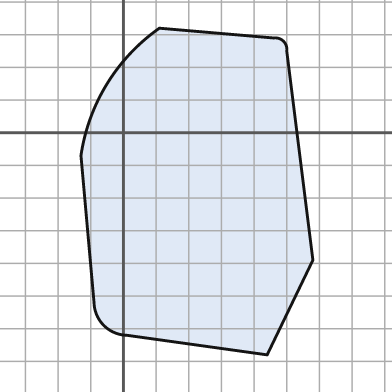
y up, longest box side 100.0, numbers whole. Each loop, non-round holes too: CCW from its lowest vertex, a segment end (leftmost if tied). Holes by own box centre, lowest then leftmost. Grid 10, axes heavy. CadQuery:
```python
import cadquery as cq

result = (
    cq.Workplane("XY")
    .moveTo(44.0, -68.0)
    .lineTo(58.0, -39.0)
    .lineTo(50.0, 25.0)
    .threePointArc((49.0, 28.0), (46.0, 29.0))
    .lineTo(11.0, 32.0)
    .threePointArc((-5.0, 15.0), (-13.0, -7.0))
    .lineTo(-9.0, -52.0)
    .threePointArc((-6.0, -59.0), (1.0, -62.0))
    .close()
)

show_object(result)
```